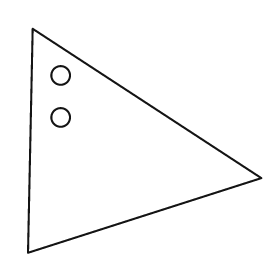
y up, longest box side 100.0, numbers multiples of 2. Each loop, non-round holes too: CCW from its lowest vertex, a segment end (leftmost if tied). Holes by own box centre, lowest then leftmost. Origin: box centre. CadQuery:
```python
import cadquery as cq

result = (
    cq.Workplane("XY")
    .moveTo(-50.0, -48.0)
    .lineTo(50.0, -16.0)
    .lineTo(-48.0, 48.0)
    .close()
    .moveTo(-36.0, 10.0)
    .circle(4.0)
    .moveTo(-36.0, 28.0)
    .circle(4.0)
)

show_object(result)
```